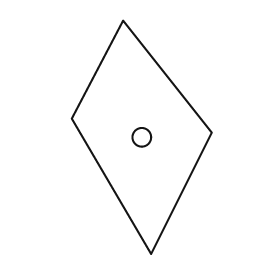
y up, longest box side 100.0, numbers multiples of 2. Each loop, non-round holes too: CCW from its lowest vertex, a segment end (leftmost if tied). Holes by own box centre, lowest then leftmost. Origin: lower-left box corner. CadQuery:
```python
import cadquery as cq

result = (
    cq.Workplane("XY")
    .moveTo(34.0, 0.0)
    .lineTo(60.0, 52.0)
    .lineTo(22.0, 100.0)
    .lineTo(0.0, 58.0)
    .close()
    .moveTo(30.0, 50.0)
    .circle(4.0)
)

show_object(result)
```